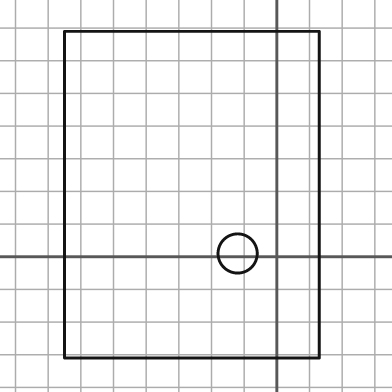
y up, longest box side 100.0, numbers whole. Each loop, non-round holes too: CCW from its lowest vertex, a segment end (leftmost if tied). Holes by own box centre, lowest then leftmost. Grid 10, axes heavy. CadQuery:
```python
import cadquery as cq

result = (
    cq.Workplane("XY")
    .moveTo(-65.0, -31.0)
    .lineTo(13.0, -31.0)
    .lineTo(13.0, 69.0)
    .lineTo(-65.0, 69.0)
    .close()
    .moveTo(-12.0, 1.0)
    .circle(6.0)
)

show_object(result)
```